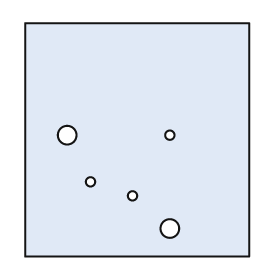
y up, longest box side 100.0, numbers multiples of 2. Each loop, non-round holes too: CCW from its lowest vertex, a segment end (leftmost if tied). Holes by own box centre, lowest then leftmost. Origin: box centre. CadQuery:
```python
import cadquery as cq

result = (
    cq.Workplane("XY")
    .moveTo(-48.0, -50.0)
    .lineTo(48.0, -50.0)
    .lineTo(48.0, 50.0)
    .lineTo(-48.0, 50.0)
    .close()
    .moveTo(14.0, -38.0)
    .circle(4.0)
    .moveTo(-2.0, -24.0)
    .circle(2.0)
    .moveTo(-20.0, -18.0)
    .circle(2.0)
    .moveTo(-30.0, 2.0)
    .circle(4.0)
    .moveTo(14.0, 2.0)
    .circle(2.0)
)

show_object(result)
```